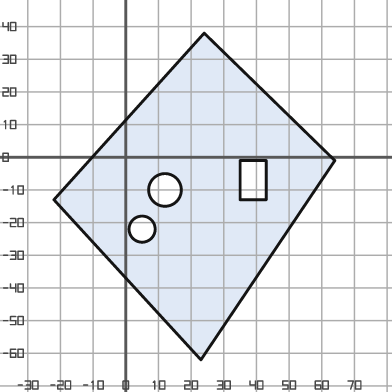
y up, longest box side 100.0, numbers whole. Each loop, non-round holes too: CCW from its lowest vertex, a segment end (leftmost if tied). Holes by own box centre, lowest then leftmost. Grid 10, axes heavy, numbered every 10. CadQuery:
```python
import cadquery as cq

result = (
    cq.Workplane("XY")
    .moveTo(23.0, -62.0)
    .lineTo(64.0, -1.0)
    .lineTo(24.0, 38.0)
    .lineTo(-22.0, -13.0)
    .close()
    .moveTo(5.0, -22.0)
    .circle(4.0)
    .moveTo(12.0, -10.0)
    .circle(5.0)
    .moveTo(35.0, -13.0)
    .lineTo(43.0, -13.0)
    .lineTo(43.0, -1.0)
    .lineTo(35.0, -1.0)
    .close()
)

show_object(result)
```